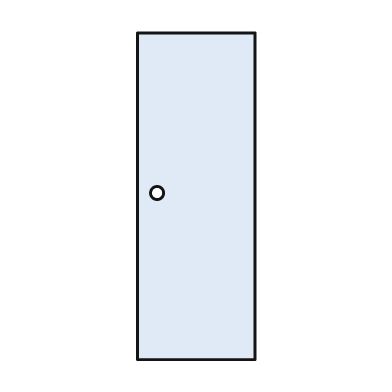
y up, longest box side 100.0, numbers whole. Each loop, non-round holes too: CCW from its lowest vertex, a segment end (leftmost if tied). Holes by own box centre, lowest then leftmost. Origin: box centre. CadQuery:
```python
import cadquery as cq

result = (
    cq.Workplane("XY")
    .moveTo(-18.0, -50.0)
    .lineTo(18.0, -50.0)
    .lineTo(18.0, 50.0)
    .lineTo(-18.0, 50.0)
    .close()
    .moveTo(-12.0, 1.0)
    .circle(2.0)
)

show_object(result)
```